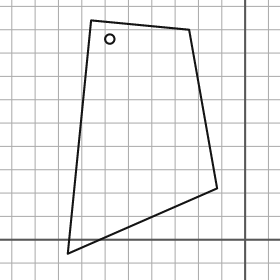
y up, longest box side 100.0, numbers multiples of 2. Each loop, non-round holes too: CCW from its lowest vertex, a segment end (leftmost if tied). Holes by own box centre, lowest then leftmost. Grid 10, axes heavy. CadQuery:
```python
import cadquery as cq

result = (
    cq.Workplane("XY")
    .moveTo(-76.0, -6.0)
    .lineTo(-12.0, 22.0)
    .lineTo(-24.0, 90.0)
    .lineTo(-66.0, 94.0)
    .close()
    .moveTo(-58.0, 86.0)
    .circle(2.0)
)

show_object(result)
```